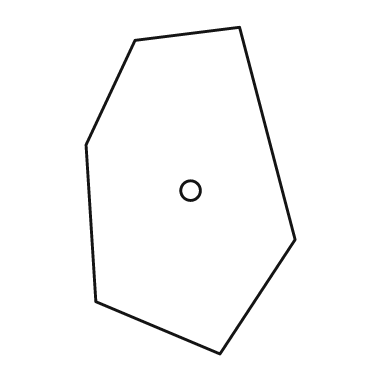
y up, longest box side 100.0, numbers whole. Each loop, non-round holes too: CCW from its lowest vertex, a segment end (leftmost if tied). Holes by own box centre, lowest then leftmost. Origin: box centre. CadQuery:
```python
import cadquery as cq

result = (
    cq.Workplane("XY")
    .moveTo(9.0, -50.0)
    .lineTo(32.0, -15.0)
    .lineTo(15.0, 50.0)
    .lineTo(-17.0, 46.0)
    .lineTo(-32.0, 14.0)
    .lineTo(-29.0, -34.0)
    .close()
    .moveTo(0.0, 0.0)
    .circle(3.0)
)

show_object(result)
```